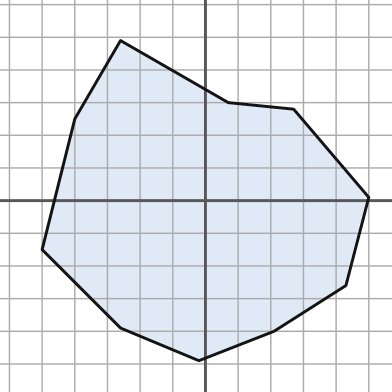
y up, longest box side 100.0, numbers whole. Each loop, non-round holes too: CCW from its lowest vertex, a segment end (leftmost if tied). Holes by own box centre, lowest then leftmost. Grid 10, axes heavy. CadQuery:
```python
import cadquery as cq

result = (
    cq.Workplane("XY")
    .moveTo(-2.0, -49.0)
    .lineTo(21.0, -40.0)
    .lineTo(43.0, -26.0)
    .lineTo(50.0, 1.0)
    .lineTo(27.0, 28.0)
    .lineTo(7.0, 30.0)
    .lineTo(-26.0, 49.0)
    .lineTo(-40.0, 25.0)
    .lineTo(-50.0, -15.0)
    .lineTo(-26.0, -39.0)
    .close()
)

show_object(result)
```